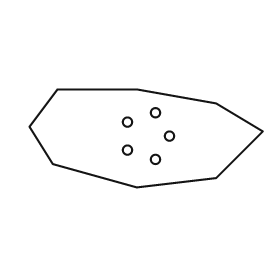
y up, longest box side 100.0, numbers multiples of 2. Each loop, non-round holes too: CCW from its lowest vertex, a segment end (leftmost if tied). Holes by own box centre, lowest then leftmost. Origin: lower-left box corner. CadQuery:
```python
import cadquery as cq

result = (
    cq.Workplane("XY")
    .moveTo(46.0, 0.0)
    .lineTo(80.0, 4.0)
    .lineTo(100.0, 24.0)
    .lineTo(80.0, 36.0)
    .lineTo(46.0, 42.0)
    .lineTo(12.0, 42.0)
    .lineTo(0.0, 26.0)
    .lineTo(10.0, 10.0)
    .close()
    .moveTo(54.0, 12.0)
    .circle(2.0)
    .moveTo(42.0, 16.0)
    .circle(2.0)
    .moveTo(60.0, 22.0)
    .circle(2.0)
    .moveTo(42.0, 28.0)
    .circle(2.0)
    .moveTo(54.0, 32.0)
    .circle(2.0)
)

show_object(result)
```